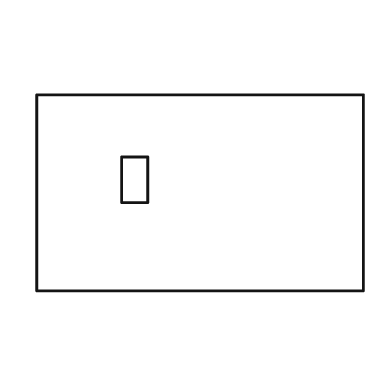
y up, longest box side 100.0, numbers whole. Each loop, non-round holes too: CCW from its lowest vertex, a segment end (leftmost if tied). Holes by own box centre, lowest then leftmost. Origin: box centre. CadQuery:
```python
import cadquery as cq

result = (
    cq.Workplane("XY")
    .moveTo(-50.0, -30.0)
    .lineTo(50.0, -30.0)
    .lineTo(50.0, 30.0)
    .lineTo(-50.0, 30.0)
    .close()
    .moveTo(-24.0, -3.0)
    .lineTo(-16.0, -3.0)
    .lineTo(-16.0, 11.0)
    .lineTo(-24.0, 11.0)
    .close()
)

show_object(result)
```